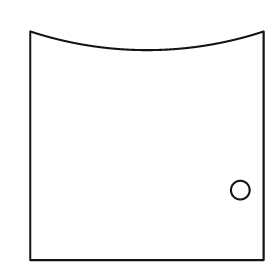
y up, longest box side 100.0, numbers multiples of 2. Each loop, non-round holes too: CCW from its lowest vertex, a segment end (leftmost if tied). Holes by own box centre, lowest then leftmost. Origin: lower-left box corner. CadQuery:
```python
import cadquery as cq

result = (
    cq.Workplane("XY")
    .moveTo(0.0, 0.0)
    .lineTo(100.0, 0.0)
    .lineTo(100.0, 98.0)
    .threePointArc((50.0, 90.0), (0.0, 98.0))
    .close()
    .moveTo(90.0, 30.0)
    .circle(4.0)
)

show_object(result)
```